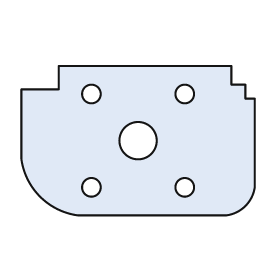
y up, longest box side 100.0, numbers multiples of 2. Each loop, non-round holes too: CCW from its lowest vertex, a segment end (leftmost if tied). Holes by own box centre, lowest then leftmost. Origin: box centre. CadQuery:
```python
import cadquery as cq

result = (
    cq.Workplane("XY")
    .moveTo(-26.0, -32.0)
    .lineTo(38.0, -32.0)
    .threePointArc((46.0, -28.0), (50.0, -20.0))
    .lineTo(50.0, 18.0)
    .lineTo(46.0, 18.0)
    .lineTo(46.0, 24.0)
    .lineTo(40.0, 24.0)
    .lineTo(40.0, 32.0)
    .lineTo(-34.0, 32.0)
    .lineTo(-34.0, 22.0)
    .lineTo(-50.0, 22.0)
    .lineTo(-50.0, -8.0)
    .threePointArc((-42.0, -24.0), (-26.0, -32.0))
    .close()
    .moveTo(-20.0, -20.0)
    .circle(4.0)
    .moveTo(20.0, -20.0)
    .circle(4.0)
    .moveTo(0.0, 0.0)
    .circle(8.0)
    .moveTo(-20.0, 20.0)
    .circle(4.0)
    .moveTo(20.0, 20.0)
    .circle(4.0)
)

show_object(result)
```